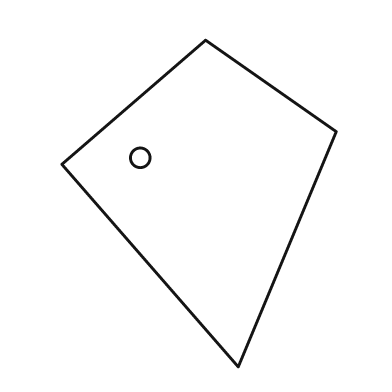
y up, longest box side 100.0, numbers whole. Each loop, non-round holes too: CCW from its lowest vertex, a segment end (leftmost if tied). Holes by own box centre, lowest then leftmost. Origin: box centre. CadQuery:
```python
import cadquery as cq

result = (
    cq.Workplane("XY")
    .moveTo(12.0, -50.0)
    .lineTo(42.0, 22.0)
    .lineTo(2.0, 50.0)
    .lineTo(-42.0, 12.0)
    .close()
    .moveTo(-18.0, 14.0)
    .circle(3.0)
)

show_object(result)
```